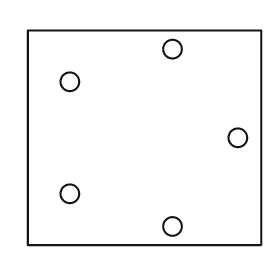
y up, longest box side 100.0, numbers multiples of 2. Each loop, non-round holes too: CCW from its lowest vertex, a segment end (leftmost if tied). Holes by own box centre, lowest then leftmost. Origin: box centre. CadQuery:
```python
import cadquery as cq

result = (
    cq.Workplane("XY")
    .moveTo(-50.0, -46.0)
    .lineTo(50.0, -46.0)
    .lineTo(50.0, 46.0)
    .lineTo(-50.0, 46.0)
    .close()
    .moveTo(12.0, -38.0)
    .circle(4.0)
    .moveTo(-32.0, -24.0)
    .circle(4.0)
    .moveTo(40.0, 0.0)
    .circle(4.0)
    .moveTo(-32.0, 24.0)
    .circle(4.0)
    .moveTo(12.0, 38.0)
    .circle(4.0)
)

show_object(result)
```